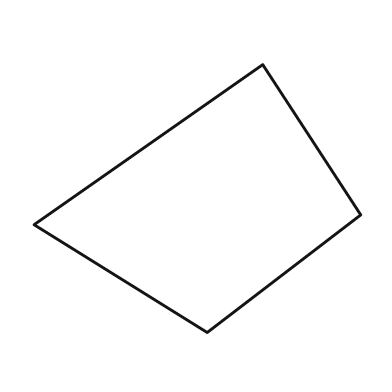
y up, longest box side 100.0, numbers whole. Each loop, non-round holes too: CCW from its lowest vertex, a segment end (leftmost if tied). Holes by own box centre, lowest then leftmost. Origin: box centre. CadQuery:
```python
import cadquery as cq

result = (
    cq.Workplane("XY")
    .moveTo(3.0, -41.0)
    .lineTo(50.0, -5.0)
    .lineTo(20.0, 41.0)
    .lineTo(-50.0, -8.0)
    .close()
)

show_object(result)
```